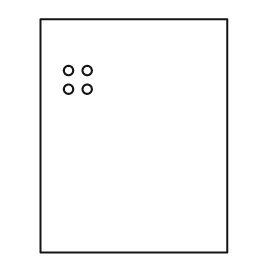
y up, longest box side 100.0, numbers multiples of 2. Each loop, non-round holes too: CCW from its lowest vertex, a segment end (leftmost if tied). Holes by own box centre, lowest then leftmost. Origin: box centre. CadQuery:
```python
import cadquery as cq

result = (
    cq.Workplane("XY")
    .moveTo(-40.0, -50.0)
    .lineTo(40.0, -50.0)
    .lineTo(40.0, 50.0)
    .lineTo(-40.0, 50.0)
    .close()
    .moveTo(-28.0, 20.0)
    .circle(2.0)
    .moveTo(-20.0, 20.0)
    .circle(2.0)
    .moveTo(-28.0, 28.0)
    .circle(2.0)
    .moveTo(-20.0, 28.0)
    .circle(2.0)
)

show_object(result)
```